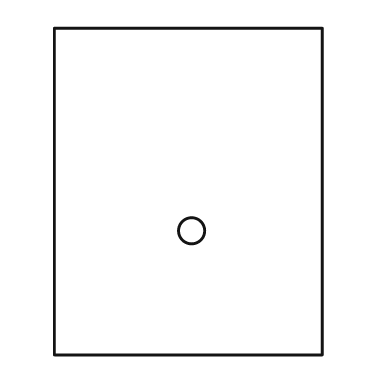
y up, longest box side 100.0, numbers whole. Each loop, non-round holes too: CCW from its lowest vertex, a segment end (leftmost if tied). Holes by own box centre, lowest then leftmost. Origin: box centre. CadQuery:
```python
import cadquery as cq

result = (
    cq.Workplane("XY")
    .moveTo(-41.0, -50.0)
    .lineTo(41.0, -50.0)
    .lineTo(41.0, 50.0)
    .lineTo(-41.0, 50.0)
    .close()
    .moveTo(1.0, -12.0)
    .circle(4.0)
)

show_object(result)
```